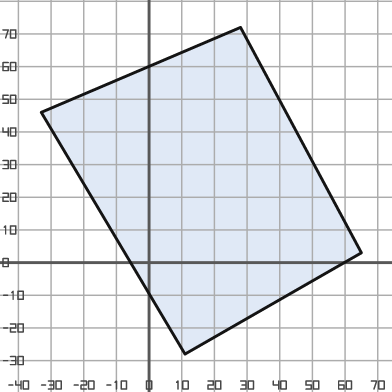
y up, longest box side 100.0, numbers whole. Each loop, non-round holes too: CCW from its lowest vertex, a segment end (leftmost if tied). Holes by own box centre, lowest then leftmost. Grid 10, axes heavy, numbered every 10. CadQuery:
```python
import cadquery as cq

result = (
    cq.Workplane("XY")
    .moveTo(11.0, -28.0)
    .lineTo(65.0, 3.0)
    .lineTo(28.0, 72.0)
    .lineTo(-33.0, 46.0)
    .close()
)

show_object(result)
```